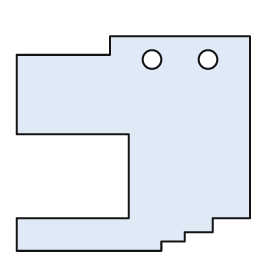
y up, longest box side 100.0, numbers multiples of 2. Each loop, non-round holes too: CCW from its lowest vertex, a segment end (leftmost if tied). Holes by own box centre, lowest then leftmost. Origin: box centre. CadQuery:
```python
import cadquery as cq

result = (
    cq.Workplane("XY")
    .moveTo(-50.0, -46.0)
    .lineTo(12.0, -46.0)
    .lineTo(12.0, -42.0)
    .lineTo(22.0, -42.0)
    .lineTo(22.0, -38.0)
    .lineTo(34.0, -38.0)
    .lineTo(34.0, -32.0)
    .lineTo(50.0, -32.0)
    .lineTo(50.0, 46.0)
    .lineTo(-10.0, 46.0)
    .lineTo(-10.0, 38.0)
    .lineTo(-50.0, 38.0)
    .lineTo(-50.0, 4.0)
    .lineTo(-2.0, 4.0)
    .lineTo(-2.0, -32.0)
    .lineTo(-50.0, -32.0)
    .close()
    .moveTo(8.0, 36.0)
    .circle(4.0)
    .moveTo(32.0, 36.0)
    .circle(4.0)
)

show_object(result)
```